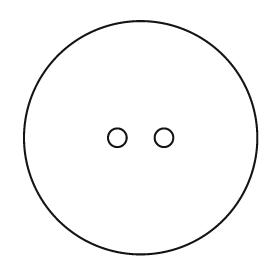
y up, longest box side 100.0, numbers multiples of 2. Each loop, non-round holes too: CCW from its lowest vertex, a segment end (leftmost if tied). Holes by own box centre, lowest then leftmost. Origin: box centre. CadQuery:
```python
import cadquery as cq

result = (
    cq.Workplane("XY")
    .moveTo(0.0, 0.0)
    .circle(50.0)
    .moveTo(-10.0, 0.0)
    .circle(4.0)
    .moveTo(10.0, 0.0)
    .circle(4.0)
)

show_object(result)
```